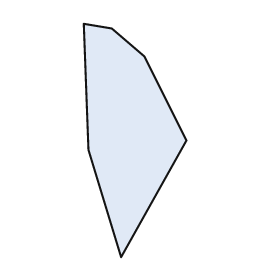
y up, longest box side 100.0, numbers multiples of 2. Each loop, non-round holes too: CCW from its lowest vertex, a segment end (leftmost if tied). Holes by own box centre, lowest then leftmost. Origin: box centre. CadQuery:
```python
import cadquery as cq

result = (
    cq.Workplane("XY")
    .moveTo(-6.0, -50.0)
    .lineTo(22.0, 0.0)
    .lineTo(4.0, 36.0)
    .lineTo(-10.0, 48.0)
    .lineTo(-22.0, 50.0)
    .lineTo(-20.0, -4.0)
    .close()
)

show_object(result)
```